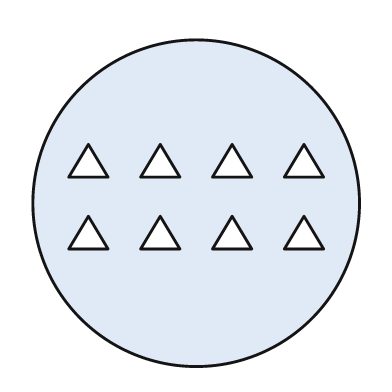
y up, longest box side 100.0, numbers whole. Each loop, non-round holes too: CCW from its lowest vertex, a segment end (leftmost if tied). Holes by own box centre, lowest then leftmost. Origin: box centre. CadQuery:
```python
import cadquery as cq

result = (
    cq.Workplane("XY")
    .moveTo(0.0, 0.0)
    .circle(50.0)
    .moveTo(-39.0, -14.0)
    .lineTo(-27.0, -14.0)
    .lineTo(-33.0, -4.0)
    .close()
    .moveTo(-17.0, -14.0)
    .lineTo(-5.0, -14.0)
    .lineTo(-11.0, -4.0)
    .close()
    .moveTo(5.0, -14.0)
    .lineTo(17.0, -14.0)
    .lineTo(11.0, -4.0)
    .close()
    .moveTo(27.0, -14.0)
    .lineTo(39.0, -14.0)
    .lineTo(33.0, -4.0)
    .close()
    .moveTo(-39.0, 8.0)
    .lineTo(-27.0, 8.0)
    .lineTo(-33.0, 18.0)
    .close()
    .moveTo(-17.0, 8.0)
    .lineTo(-5.0, 8.0)
    .lineTo(-11.0, 18.0)
    .close()
    .moveTo(5.0, 8.0)
    .lineTo(17.0, 8.0)
    .lineTo(11.0, 18.0)
    .close()
    .moveTo(27.0, 8.0)
    .lineTo(39.0, 8.0)
    .lineTo(33.0, 18.0)
    .close()
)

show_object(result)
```